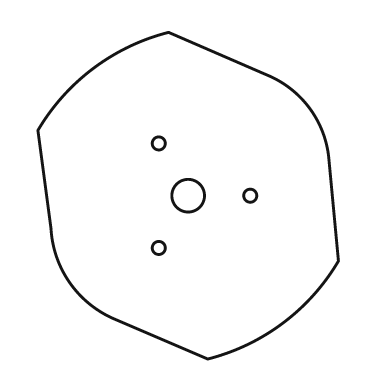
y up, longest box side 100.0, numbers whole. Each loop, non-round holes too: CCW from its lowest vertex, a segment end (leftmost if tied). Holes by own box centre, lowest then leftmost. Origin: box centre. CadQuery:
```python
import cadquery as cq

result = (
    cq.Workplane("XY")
    .moveTo(6.0, -50.0)
    .threePointArc((29.0, -39.0), (46.0, -20.0))
    .lineTo(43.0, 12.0)
    .threePointArc((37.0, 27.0), (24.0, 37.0))
    .lineTo(-6.0, 50.0)
    .threePointArc((-29.0, 39.0), (-46.0, 20.0))
    .lineTo(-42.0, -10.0)
    .threePointArc((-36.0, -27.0), (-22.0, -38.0))
    .close()
    .moveTo(-9.0, -16.0)
    .circle(2.0)
    .moveTo(0.0, 0.0)
    .circle(5.0)
    .moveTo(19.0, 0.0)
    .circle(2.0)
    .moveTo(-9.0, 16.0)
    .circle(2.0)
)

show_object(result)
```